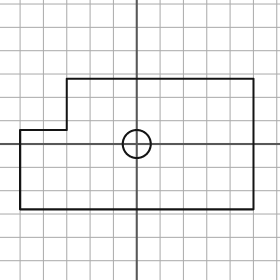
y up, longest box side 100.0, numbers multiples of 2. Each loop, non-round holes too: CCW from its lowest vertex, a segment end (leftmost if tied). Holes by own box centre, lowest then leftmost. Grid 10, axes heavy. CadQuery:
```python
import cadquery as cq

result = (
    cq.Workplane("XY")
    .moveTo(-50.0, -28.0)
    .lineTo(50.0, -28.0)
    .lineTo(50.0, 28.0)
    .lineTo(-30.0, 28.0)
    .lineTo(-30.0, 6.0)
    .lineTo(-50.0, 6.0)
    .close()
    .moveTo(0.0, 0.0)
    .circle(6.0)
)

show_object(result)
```